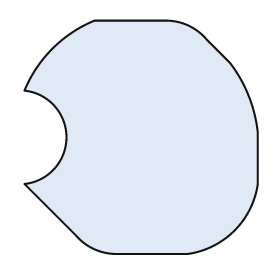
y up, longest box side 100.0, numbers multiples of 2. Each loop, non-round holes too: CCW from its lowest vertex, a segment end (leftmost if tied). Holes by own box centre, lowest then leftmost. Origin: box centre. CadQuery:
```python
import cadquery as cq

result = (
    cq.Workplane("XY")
    .moveTo(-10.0, -50.0)
    .lineTo(20.0, -50.0)
    .threePointArc((40.0, -40.0), (50.0, -20.0))
    .lineTo(50.0, 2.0)
    .threePointArc((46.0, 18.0), (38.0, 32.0))
    .lineTo(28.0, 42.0)
    .threePointArc((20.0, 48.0), (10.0, 50.0))
    .lineTo(-20.0, 50.0)
    .threePointArc((-38.0, 38.0), (-50.0, 20.0))
    .threePointArc((-32.0, 0.0), (-50.0, -20.0))
    .lineTo(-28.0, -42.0)
    .threePointArc((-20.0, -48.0), (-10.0, -50.0))
    .close()
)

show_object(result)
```